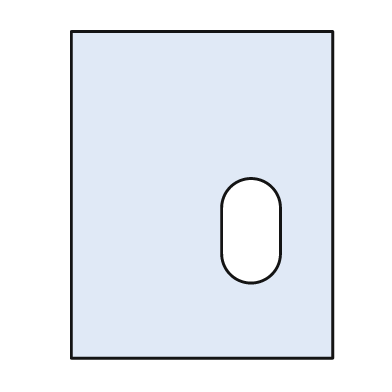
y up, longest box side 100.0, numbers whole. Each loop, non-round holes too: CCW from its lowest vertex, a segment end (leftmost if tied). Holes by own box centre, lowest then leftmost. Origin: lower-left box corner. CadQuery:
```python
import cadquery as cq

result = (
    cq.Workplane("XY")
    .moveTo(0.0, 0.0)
    .lineTo(80.0, 0.0)
    .lineTo(80.0, 100.0)
    .lineTo(0.0, 100.0)
    .close()
    .moveTo(46.0, 32.0)
    .threePointArc((55.0, 23.0), (64.0, 32.0))
    .lineTo(64.0, 46.0)
    .threePointArc((55.0, 55.0), (46.0, 46.0))
    .close()
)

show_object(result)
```